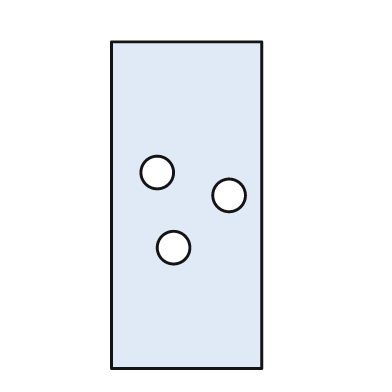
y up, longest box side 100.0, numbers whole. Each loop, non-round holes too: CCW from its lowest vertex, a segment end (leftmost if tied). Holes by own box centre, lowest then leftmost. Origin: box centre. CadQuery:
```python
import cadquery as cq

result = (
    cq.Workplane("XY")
    .moveTo(-23.0, -50.0)
    .lineTo(23.0, -50.0)
    .lineTo(23.0, 50.0)
    .lineTo(-23.0, 50.0)
    .close()
    .moveTo(-4.0, -13.0)
    .circle(5.0)
    .moveTo(13.0, 3.0)
    .circle(5.0)
    .moveTo(-9.0, 10.0)
    .circle(5.0)
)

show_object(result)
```